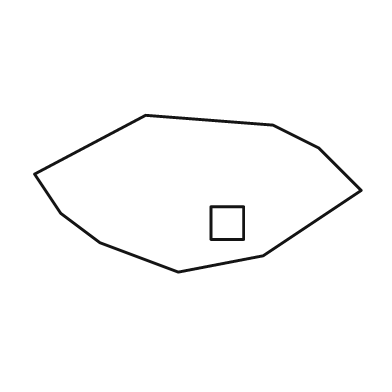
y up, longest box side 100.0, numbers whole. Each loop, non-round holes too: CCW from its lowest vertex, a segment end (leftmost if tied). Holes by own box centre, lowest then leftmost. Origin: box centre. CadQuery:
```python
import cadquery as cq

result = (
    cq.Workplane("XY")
    .moveTo(-6.0, -24.0)
    .lineTo(20.0, -19.0)
    .lineTo(50.0, 1.0)
    .lineTo(37.0, 14.0)
    .lineTo(23.0, 21.0)
    .lineTo(-16.0, 24.0)
    .lineTo(-50.0, 6.0)
    .lineTo(-42.0, -6.0)
    .lineTo(-30.0, -15.0)
    .close()
    .moveTo(4.0, -14.0)
    .lineTo(14.0, -14.0)
    .lineTo(14.0, -4.0)
    .lineTo(4.0, -4.0)
    .close()
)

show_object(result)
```